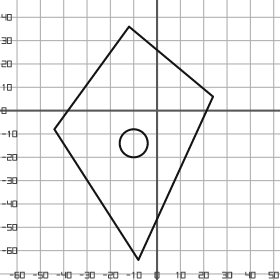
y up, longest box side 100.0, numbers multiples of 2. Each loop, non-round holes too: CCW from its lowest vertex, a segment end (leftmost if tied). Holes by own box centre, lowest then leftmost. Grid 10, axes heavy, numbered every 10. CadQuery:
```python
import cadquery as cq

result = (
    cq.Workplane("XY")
    .moveTo(-8.0, -64.0)
    .lineTo(24.0, 6.0)
    .lineTo(-12.0, 36.0)
    .lineTo(-44.0, -8.0)
    .close()
    .moveTo(-10.0, -14.0)
    .circle(6.0)
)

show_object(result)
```